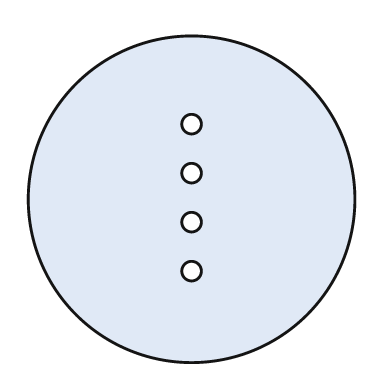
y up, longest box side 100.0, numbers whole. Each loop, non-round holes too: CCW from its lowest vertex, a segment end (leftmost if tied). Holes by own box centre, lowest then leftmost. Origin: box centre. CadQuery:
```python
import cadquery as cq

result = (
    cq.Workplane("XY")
    .moveTo(0.0, 0.0)
    .circle(50.0)
    .moveTo(0.0, -22.0)
    .circle(3.0)
    .moveTo(0.0, -7.0)
    .circle(3.0)
    .moveTo(0.0, 8.0)
    .circle(3.0)
    .moveTo(0.0, 23.0)
    .circle(3.0)
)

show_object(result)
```